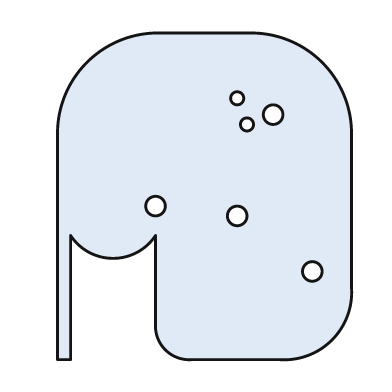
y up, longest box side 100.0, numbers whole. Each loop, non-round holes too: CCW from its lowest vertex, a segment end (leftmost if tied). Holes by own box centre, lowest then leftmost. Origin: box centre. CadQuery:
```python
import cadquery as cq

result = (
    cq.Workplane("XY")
    .moveTo(-45.0, -50.0)
    .lineTo(-41.0, -50.0)
    .lineTo(-41.0, -12.0)
    .threePointArc((-28.0, -19.0), (-15.0, -12.0))
    .lineTo(-15.0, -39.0)
    .threePointArc((-12.0, -47.0), (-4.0, -50.0))
    .lineTo(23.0, -50.0)
    .threePointArc((39.0, -44.0), (45.0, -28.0))
    .lineTo(45.0, 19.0)
    .threePointArc((36.0, 41.0), (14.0, 50.0))
    .lineTo(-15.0, 50.0)
    .threePointArc((-36.0, 41.0), (-45.0, 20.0))
    .close()
    .moveTo(33.0, -23.0)
    .circle(3.0)
    .moveTo(10.0, -6.0)
    .circle(3.0)
    .moveTo(-15.0, -3.0)
    .circle(3.0)
    .moveTo(13.0, 22.0)
    .circle(2.0)
    .moveTo(21.0, 25.0)
    .circle(3.0)
    .moveTo(10.0, 30.0)
    .circle(2.0)
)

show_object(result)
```